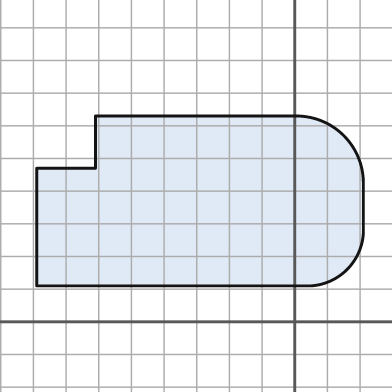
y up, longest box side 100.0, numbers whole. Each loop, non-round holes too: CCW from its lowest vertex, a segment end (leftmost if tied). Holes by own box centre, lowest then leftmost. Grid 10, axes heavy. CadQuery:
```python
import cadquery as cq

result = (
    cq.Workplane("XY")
    .moveTo(-79.0, 11.0)
    .lineTo(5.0, 11.0)
    .threePointArc((16.0, 16.0), (21.0, 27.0))
    .lineTo(21.0, 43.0)
    .threePointArc((15.0, 57.0), (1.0, 63.0))
    .lineTo(-61.0, 63.0)
    .lineTo(-61.0, 47.0)
    .lineTo(-79.0, 47.0)
    .close()
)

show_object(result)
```